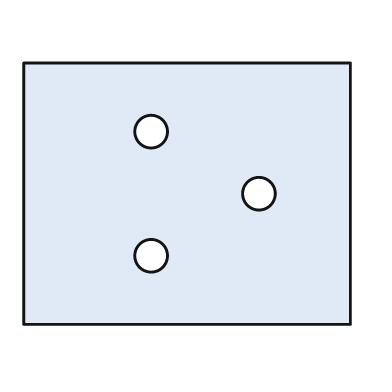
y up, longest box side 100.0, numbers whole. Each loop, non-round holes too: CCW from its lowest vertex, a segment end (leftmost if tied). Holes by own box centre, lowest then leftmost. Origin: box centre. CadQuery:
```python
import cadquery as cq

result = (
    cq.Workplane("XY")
    .moveTo(-50.0, -40.0)
    .lineTo(50.0, -40.0)
    .lineTo(50.0, 40.0)
    .lineTo(-50.0, 40.0)
    .close()
    .moveTo(-11.0, -19.0)
    .circle(5.0)
    .moveTo(22.0, 0.0)
    .circle(5.0)
    .moveTo(-11.0, 19.0)
    .circle(5.0)
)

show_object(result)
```